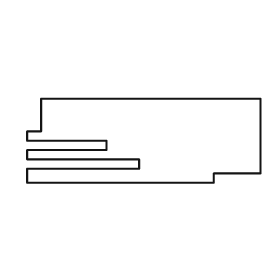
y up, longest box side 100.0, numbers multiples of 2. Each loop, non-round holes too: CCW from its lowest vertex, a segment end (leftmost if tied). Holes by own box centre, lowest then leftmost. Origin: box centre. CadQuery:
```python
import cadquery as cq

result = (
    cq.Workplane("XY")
    .moveTo(-50.0, -18.0)
    .lineTo(30.0, -18.0)
    .lineTo(30.0, -14.0)
    .lineTo(50.0, -14.0)
    .lineTo(50.0, 18.0)
    .lineTo(-44.0, 18.0)
    .lineTo(-44.0, 4.0)
    .lineTo(-50.0, 4.0)
    .lineTo(-50.0, 0.0)
    .lineTo(-16.0, 0.0)
    .lineTo(-16.0, -4.0)
    .lineTo(-50.0, -4.0)
    .lineTo(-50.0, -8.0)
    .lineTo(-2.0, -8.0)
    .lineTo(-2.0, -12.0)
    .lineTo(-50.0, -12.0)
    .close()
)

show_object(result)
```